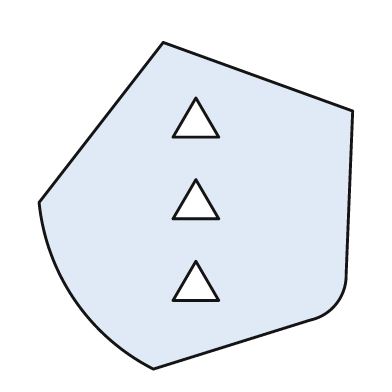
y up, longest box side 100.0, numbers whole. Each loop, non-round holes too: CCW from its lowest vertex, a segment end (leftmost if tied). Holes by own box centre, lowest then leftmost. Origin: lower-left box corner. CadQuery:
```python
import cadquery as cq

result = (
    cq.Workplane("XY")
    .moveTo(35.0, 0.0)
    .lineTo(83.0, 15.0)
    .threePointArc((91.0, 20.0), (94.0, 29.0))
    .lineTo(96.0, 79.0)
    .lineTo(38.0, 100.0)
    .lineTo(0.0, 51.0)
    .threePointArc((11.0, 21.0), (35.0, 0.0))
    .close()
    .moveTo(41.0, 21.0)
    .lineTo(55.0, 21.0)
    .lineTo(48.0, 33.0)
    .close()
    .moveTo(41.0, 46.0)
    .lineTo(55.0, 46.0)
    .lineTo(48.0, 58.0)
    .close()
    .moveTo(41.0, 71.0)
    .lineTo(55.0, 71.0)
    .lineTo(48.0, 83.0)
    .close()
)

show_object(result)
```